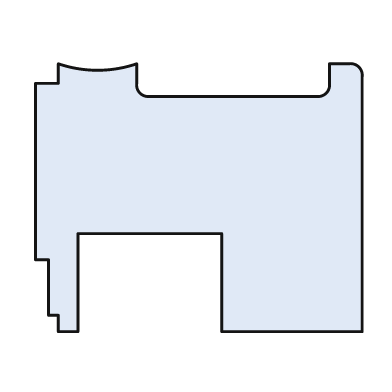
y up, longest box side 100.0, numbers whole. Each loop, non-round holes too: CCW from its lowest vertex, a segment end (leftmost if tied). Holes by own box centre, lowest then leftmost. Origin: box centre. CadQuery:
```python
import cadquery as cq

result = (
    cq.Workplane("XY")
    .moveTo(-43.0, -41.0)
    .lineTo(-37.0, -41.0)
    .lineTo(-37.0, -11.0)
    .lineTo(7.0, -11.0)
    .lineTo(7.0, -41.0)
    .lineTo(50.0, -41.0)
    .lineTo(50.0, 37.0)
    .threePointArc((49.0, 40.0), (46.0, 41.0))
    .lineTo(40.0, 41.0)
    .lineTo(40.0, 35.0)
    .threePointArc((39.0, 32.0), (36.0, 31.0))
    .lineTo(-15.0, 31.0)
    .threePointArc((-18.0, 32.0), (-19.0, 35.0))
    .lineTo(-19.0, 41.0)
    .threePointArc((-31.0, 39.0), (-43.0, 41.0))
    .lineTo(-43.0, 35.0)
    .lineTo(-50.0, 35.0)
    .lineTo(-50.0, -19.0)
    .lineTo(-46.0, -19.0)
    .lineTo(-46.0, -36.0)
    .lineTo(-43.0, -36.0)
    .close()
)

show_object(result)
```